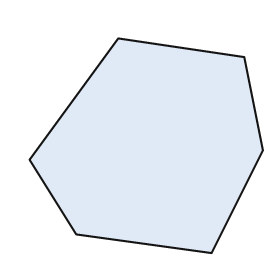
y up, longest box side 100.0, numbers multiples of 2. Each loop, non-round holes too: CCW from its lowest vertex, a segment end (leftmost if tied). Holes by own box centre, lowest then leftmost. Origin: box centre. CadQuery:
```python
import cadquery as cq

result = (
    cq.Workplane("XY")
    .moveTo(28.0, -46.0)
    .lineTo(50.0, -2.0)
    .lineTo(42.0, 38.0)
    .lineTo(-12.0, 46.0)
    .lineTo(-50.0, -6.0)
    .lineTo(-30.0, -38.0)
    .close()
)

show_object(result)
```